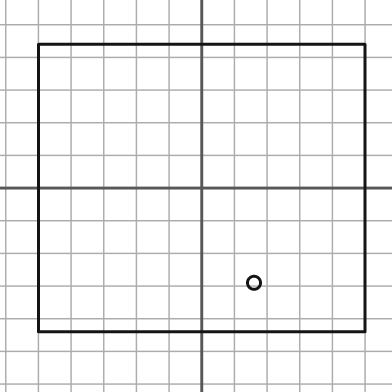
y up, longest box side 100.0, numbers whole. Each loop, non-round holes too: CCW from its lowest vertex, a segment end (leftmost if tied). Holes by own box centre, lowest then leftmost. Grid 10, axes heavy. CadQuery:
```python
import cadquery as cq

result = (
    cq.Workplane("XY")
    .moveTo(-50.0, -44.0)
    .lineTo(50.0, -44.0)
    .lineTo(50.0, 44.0)
    .lineTo(-50.0, 44.0)
    .close()
    .moveTo(16.0, -29.0)
    .circle(2.0)
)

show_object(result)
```